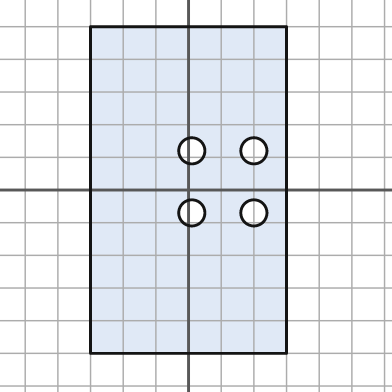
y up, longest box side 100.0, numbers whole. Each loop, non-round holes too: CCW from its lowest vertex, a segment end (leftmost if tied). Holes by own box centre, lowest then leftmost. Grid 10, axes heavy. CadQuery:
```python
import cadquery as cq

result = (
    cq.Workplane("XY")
    .moveTo(-30.0, -50.0)
    .lineTo(30.0, -50.0)
    .lineTo(30.0, 50.0)
    .lineTo(-30.0, 50.0)
    .close()
    .moveTo(1.0, -7.0)
    .circle(4.0)
    .moveTo(20.0, -7.0)
    .circle(4.0)
    .moveTo(1.0, 12.0)
    .circle(4.0)
    .moveTo(20.0, 12.0)
    .circle(4.0)
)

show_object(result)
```